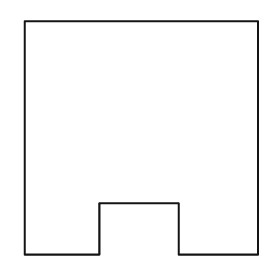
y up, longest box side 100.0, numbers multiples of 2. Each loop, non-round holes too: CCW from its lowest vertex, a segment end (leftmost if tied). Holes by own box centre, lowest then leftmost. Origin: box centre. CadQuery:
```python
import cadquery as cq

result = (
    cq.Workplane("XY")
    .moveTo(-50.0, -50.0)
    .lineTo(-18.0, -50.0)
    .lineTo(-18.0, -28.0)
    .lineTo(16.0, -28.0)
    .lineTo(16.0, -50.0)
    .lineTo(50.0, -50.0)
    .lineTo(50.0, 50.0)
    .lineTo(-50.0, 50.0)
    .close()
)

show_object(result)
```